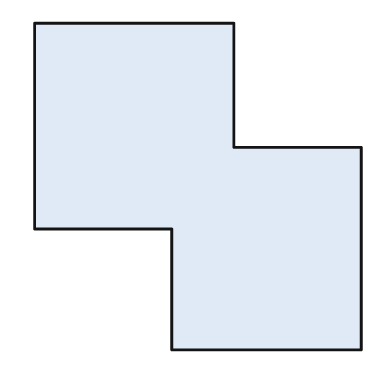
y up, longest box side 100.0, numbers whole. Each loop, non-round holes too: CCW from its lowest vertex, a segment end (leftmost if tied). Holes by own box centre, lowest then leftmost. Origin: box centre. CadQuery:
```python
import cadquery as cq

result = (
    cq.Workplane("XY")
    .moveTo(-8.0, -50.0)
    .lineTo(50.0, -50.0)
    .lineTo(50.0, 12.0)
    .lineTo(11.0, 12.0)
    .lineTo(11.0, 50.0)
    .lineTo(-50.0, 50.0)
    .lineTo(-50.0, -13.0)
    .lineTo(-8.0, -13.0)
    .close()
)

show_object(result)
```